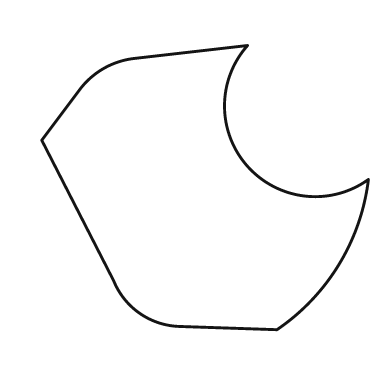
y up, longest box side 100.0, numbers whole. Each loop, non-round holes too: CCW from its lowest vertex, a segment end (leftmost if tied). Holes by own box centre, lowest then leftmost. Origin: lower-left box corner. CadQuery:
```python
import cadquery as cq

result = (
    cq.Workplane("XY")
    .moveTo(72.0, 0.0)
    .threePointArc((91.0, 20.0), (100.0, 46.0))
    .threePointArc((63.0, 50.0), (63.0, 87.0))
    .lineTo(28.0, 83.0)
    .threePointArc((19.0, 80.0), (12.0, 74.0))
    .lineTo(0.0, 58.0)
    .lineTo(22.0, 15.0)
    .threePointArc((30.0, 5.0), (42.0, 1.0))
    .close()
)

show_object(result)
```